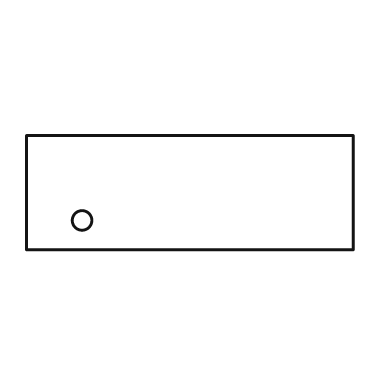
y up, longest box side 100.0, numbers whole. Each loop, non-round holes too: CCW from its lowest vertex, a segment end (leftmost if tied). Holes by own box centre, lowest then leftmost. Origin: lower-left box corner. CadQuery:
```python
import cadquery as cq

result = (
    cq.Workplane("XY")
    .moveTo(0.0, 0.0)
    .lineTo(100.0, 0.0)
    .lineTo(100.0, 35.0)
    .lineTo(0.0, 35.0)
    .close()
    .moveTo(17.0, 9.0)
    .circle(3.0)
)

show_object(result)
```